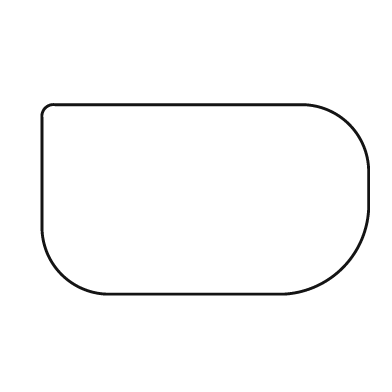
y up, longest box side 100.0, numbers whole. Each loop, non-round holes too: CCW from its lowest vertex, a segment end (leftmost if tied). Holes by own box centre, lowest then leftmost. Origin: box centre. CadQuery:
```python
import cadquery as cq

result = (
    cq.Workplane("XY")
    .moveTo(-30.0, -29.0)
    .lineTo(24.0, -29.0)
    .threePointArc((42.0, -21.0), (50.0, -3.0))
    .lineTo(50.0, 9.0)
    .threePointArc((44.0, 23.0), (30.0, 29.0))
    .lineTo(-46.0, 29.0)
    .threePointArc((-49.0, 28.0), (-50.0, 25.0))
    .lineTo(-50.0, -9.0)
    .threePointArc((-44.0, -23.0), (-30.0, -29.0))
    .close()
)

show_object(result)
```